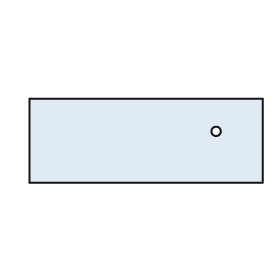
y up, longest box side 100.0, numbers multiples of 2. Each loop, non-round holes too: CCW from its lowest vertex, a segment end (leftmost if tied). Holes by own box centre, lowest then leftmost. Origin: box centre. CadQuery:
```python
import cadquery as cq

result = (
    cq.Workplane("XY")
    .moveTo(-50.0, -18.0)
    .lineTo(50.0, -18.0)
    .lineTo(50.0, 18.0)
    .lineTo(-50.0, 18.0)
    .close()
    .moveTo(30.0, 4.0)
    .circle(2.0)
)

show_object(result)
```